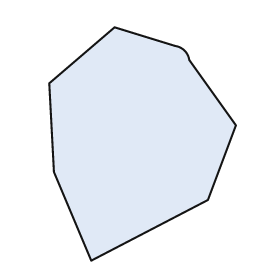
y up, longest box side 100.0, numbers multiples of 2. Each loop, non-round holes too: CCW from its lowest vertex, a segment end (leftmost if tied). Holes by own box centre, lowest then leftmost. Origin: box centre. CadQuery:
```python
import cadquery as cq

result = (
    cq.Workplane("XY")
    .moveTo(-22.0, -50.0)
    .lineTo(28.0, -24.0)
    .lineTo(40.0, 8.0)
    .lineTo(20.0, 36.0)
    .threePointArc((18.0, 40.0), (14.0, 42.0))
    .lineTo(-12.0, 50.0)
    .lineTo(-40.0, 26.0)
    .lineTo(-38.0, -12.0)
    .close()
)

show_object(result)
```